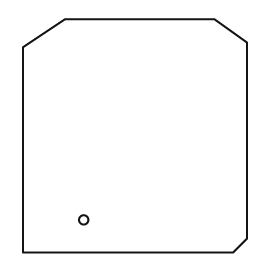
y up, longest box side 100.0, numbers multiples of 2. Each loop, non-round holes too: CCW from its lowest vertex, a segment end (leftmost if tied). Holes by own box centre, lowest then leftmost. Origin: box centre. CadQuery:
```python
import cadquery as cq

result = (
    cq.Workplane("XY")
    .moveTo(-48.0, -50.0)
    .lineTo(42.0, -50.0)
    .lineTo(48.0, -44.0)
    .lineTo(48.0, 40.0)
    .lineTo(34.0, 50.0)
    .lineTo(-30.0, 50.0)
    .lineTo(-48.0, 38.0)
    .close()
    .moveTo(-22.0, -36.0)
    .circle(2.0)
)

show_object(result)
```